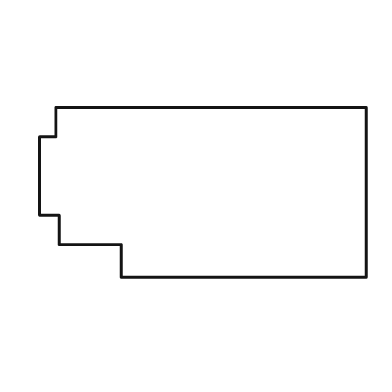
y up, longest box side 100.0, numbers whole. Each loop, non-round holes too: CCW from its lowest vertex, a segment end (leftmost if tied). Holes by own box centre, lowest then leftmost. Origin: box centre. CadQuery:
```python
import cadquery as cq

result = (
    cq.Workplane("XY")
    .moveTo(-25.0, -26.0)
    .lineTo(50.0, -26.0)
    .lineTo(50.0, 26.0)
    .lineTo(-45.0, 26.0)
    .lineTo(-45.0, 17.0)
    .lineTo(-50.0, 17.0)
    .lineTo(-50.0, -7.0)
    .lineTo(-44.0, -7.0)
    .lineTo(-44.0, -16.0)
    .lineTo(-25.0, -16.0)
    .close()
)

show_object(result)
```